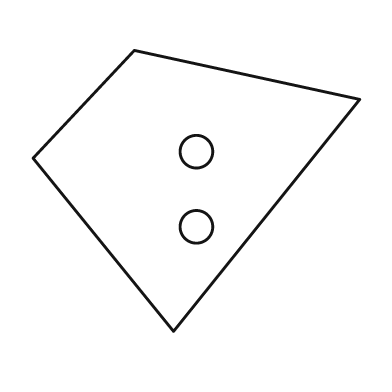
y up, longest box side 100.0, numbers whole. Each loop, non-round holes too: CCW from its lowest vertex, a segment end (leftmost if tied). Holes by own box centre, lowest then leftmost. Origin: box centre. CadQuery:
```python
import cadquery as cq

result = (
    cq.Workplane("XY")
    .moveTo(-7.0, -43.0)
    .lineTo(50.0, 28.0)
    .lineTo(-19.0, 43.0)
    .lineTo(-50.0, 10.0)
    .close()
    .moveTo(0.0, -11.0)
    .circle(5.0)
    .moveTo(0.0, 12.0)
    .circle(5.0)
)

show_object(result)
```